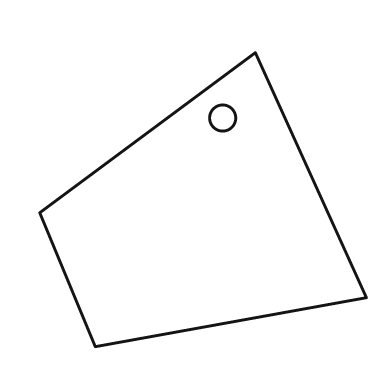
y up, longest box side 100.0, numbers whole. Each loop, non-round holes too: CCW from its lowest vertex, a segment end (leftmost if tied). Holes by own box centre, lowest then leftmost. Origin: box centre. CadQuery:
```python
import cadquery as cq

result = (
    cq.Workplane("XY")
    .moveTo(-33.0, -45.0)
    .lineTo(50.0, -30.0)
    .lineTo(16.0, 45.0)
    .lineTo(-50.0, -4.0)
    .close()
    .moveTo(6.0, 25.0)
    .circle(4.0)
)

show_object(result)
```